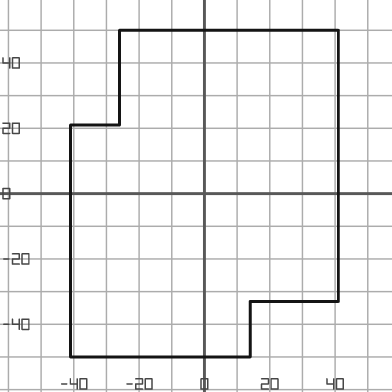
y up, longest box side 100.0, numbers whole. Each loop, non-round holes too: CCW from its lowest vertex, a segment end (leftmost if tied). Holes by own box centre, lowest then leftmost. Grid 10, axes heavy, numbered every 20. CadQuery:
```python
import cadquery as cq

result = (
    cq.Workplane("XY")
    .moveTo(-41.0, -50.0)
    .lineTo(14.0, -50.0)
    .lineTo(14.0, -33.0)
    .lineTo(41.0, -33.0)
    .lineTo(41.0, 50.0)
    .lineTo(-26.0, 50.0)
    .lineTo(-26.0, 21.0)
    .lineTo(-41.0, 21.0)
    .close()
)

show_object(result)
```